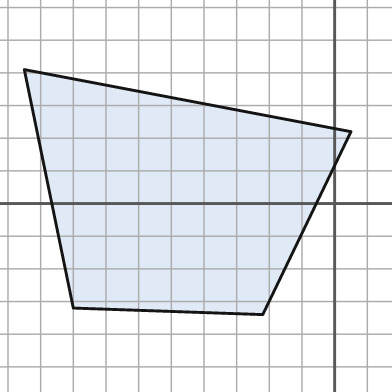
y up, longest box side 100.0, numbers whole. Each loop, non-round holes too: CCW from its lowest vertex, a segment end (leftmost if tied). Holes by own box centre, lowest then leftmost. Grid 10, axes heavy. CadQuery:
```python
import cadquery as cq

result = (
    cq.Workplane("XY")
    .moveTo(-22.0, -34.0)
    .lineTo(5.0, 22.0)
    .lineTo(-95.0, 41.0)
    .lineTo(-80.0, -32.0)
    .close()
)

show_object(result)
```